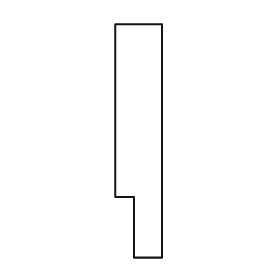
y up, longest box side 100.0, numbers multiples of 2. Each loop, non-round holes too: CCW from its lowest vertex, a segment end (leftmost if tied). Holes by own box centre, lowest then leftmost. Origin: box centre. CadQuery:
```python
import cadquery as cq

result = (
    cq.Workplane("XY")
    .moveTo(-2.0, -50.0)
    .lineTo(10.0, -50.0)
    .lineTo(10.0, 50.0)
    .lineTo(-10.0, 50.0)
    .lineTo(-10.0, -24.0)
    .lineTo(-2.0, -24.0)
    .close()
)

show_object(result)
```